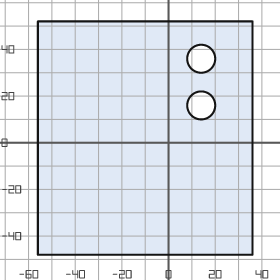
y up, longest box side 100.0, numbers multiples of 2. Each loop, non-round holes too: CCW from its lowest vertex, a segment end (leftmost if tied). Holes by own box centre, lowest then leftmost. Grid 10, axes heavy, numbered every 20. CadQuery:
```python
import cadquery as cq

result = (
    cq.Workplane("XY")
    .moveTo(-56.0, -48.0)
    .lineTo(36.0, -48.0)
    .lineTo(36.0, 52.0)
    .lineTo(-56.0, 52.0)
    .close()
    .moveTo(14.0, 16.0)
    .circle(6.0)
    .moveTo(14.0, 36.0)
    .circle(6.0)
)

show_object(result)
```